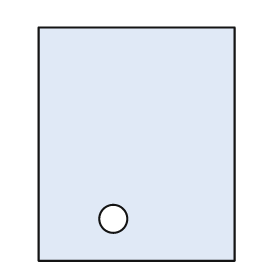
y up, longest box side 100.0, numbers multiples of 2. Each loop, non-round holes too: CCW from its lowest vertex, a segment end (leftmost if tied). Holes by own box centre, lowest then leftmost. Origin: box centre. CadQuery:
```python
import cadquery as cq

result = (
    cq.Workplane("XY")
    .moveTo(-42.0, -50.0)
    .lineTo(42.0, -50.0)
    .lineTo(42.0, 50.0)
    .lineTo(-42.0, 50.0)
    .close()
    .moveTo(-10.0, -32.0)
    .circle(6.0)
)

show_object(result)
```